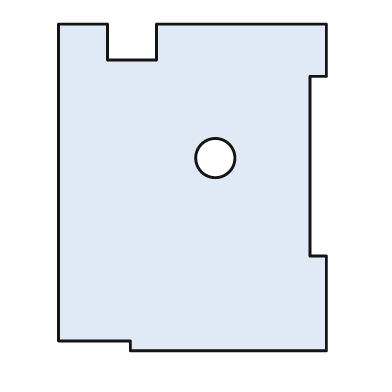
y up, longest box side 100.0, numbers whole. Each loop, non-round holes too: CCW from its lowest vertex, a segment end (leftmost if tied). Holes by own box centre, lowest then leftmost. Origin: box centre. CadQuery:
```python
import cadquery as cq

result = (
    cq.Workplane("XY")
    .moveTo(-19.0, -50.0)
    .lineTo(41.0, -50.0)
    .lineTo(41.0, -21.0)
    .lineTo(36.0, -21.0)
    .lineTo(36.0, 34.0)
    .lineTo(41.0, 34.0)
    .lineTo(41.0, 50.0)
    .lineTo(-11.0, 50.0)
    .lineTo(-11.0, 39.0)
    .lineTo(-26.0, 39.0)
    .lineTo(-26.0, 50.0)
    .lineTo(-41.0, 50.0)
    .lineTo(-41.0, -47.0)
    .lineTo(-19.0, -47.0)
    .close()
    .moveTo(7.0, 9.0)
    .circle(6.0)
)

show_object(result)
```